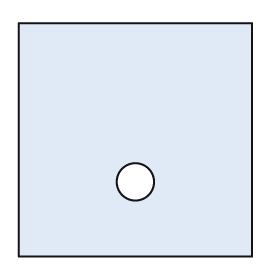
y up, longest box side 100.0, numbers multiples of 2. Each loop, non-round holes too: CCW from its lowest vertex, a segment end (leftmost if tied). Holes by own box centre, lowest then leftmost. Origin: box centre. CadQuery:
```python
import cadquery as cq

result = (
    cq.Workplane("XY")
    .moveTo(-50.0, -50.0)
    .lineTo(50.0, -50.0)
    .lineTo(50.0, 50.0)
    .lineTo(-50.0, 50.0)
    .close()
    .moveTo(0.0, -18.0)
    .circle(8.0)
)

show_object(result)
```